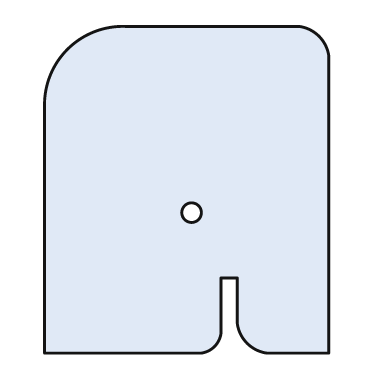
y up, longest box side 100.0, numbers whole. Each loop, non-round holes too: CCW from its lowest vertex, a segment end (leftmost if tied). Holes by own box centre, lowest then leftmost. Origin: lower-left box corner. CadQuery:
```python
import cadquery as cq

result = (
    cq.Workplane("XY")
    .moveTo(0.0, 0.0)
    .lineTo(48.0, 0.0)
    .threePointArc((52.0, 2.0), (54.0, 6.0))
    .lineTo(54.0, 23.0)
    .lineTo(59.0, 23.0)
    .lineTo(59.0, 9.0)
    .threePointArc((62.0, 3.0), (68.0, 0.0))
    .lineTo(87.0, 0.0)
    .lineTo(87.0, 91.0)
    .threePointArc((84.0, 97.0), (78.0, 100.0))
    .lineTo(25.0, 100.0)
    .threePointArc((7.0, 93.0), (0.0, 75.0))
    .close()
    .moveTo(45.0, 43.0)
    .circle(3.0)
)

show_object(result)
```